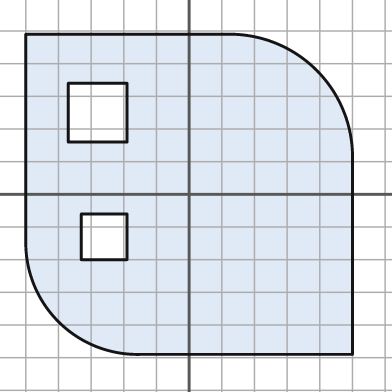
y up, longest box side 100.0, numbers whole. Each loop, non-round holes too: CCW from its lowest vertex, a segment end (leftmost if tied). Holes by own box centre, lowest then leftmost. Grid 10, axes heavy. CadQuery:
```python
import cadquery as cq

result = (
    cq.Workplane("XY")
    .moveTo(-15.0, -49.0)
    .lineTo(50.0, -49.0)
    .lineTo(50.0, 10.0)
    .threePointArc((39.0, 38.0), (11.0, 49.0))
    .lineTo(-50.0, 49.0)
    .lineTo(-50.0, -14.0)
    .threePointArc((-40.0, -39.0), (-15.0, -49.0))
    .close()
    .moveTo(-33.0, -20.0)
    .lineTo(-19.0, -20.0)
    .lineTo(-19.0, -6.0)
    .lineTo(-33.0, -6.0)
    .close()
    .moveTo(-37.0, 16.0)
    .lineTo(-19.0, 16.0)
    .lineTo(-19.0, 34.0)
    .lineTo(-37.0, 34.0)
    .close()
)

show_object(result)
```